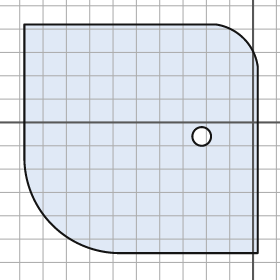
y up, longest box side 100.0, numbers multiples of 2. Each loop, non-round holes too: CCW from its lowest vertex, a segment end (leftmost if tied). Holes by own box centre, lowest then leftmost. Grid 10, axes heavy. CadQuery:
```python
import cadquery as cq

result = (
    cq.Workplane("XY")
    .moveTo(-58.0, -56.0)
    .lineTo(2.0, -56.0)
    .lineTo(2.0, 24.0)
    .threePointArc((-4.0, 36.0), (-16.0, 42.0))
    .lineTo(-98.0, 42.0)
    .lineTo(-98.0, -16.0)
    .threePointArc((-86.0, -44.0), (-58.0, -56.0))
    .close()
    .moveTo(-22.0, -6.0)
    .circle(4.0)
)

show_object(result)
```